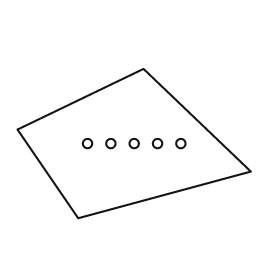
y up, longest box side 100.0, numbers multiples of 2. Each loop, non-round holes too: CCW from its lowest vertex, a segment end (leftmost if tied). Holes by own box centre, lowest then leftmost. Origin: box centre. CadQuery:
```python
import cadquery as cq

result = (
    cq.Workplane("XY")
    .moveTo(-24.0, -32.0)
    .lineTo(50.0, -12.0)
    .lineTo(4.0, 32.0)
    .lineTo(-50.0, 6.0)
    .close()
    .moveTo(-20.0, 0.0)
    .circle(2.0)
    .moveTo(-10.0, 0.0)
    .circle(2.0)
    .moveTo(0.0, 0.0)
    .circle(2.0)
    .moveTo(10.0, 0.0)
    .circle(2.0)
    .moveTo(20.0, 0.0)
    .circle(2.0)
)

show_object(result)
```